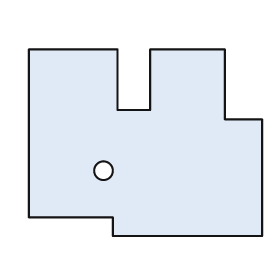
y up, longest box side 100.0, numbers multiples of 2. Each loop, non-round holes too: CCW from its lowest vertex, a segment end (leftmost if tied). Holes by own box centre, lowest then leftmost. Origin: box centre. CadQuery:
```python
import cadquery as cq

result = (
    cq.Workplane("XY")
    .moveTo(-14.0, -40.0)
    .lineTo(50.0, -40.0)
    .lineTo(50.0, 10.0)
    .lineTo(34.0, 10.0)
    .lineTo(34.0, 40.0)
    .lineTo(2.0, 40.0)
    .lineTo(2.0, 14.0)
    .lineTo(-12.0, 14.0)
    .lineTo(-12.0, 40.0)
    .lineTo(-50.0, 40.0)
    .lineTo(-50.0, -32.0)
    .lineTo(-14.0, -32.0)
    .close()
    .moveTo(-18.0, -12.0)
    .circle(4.0)
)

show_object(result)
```